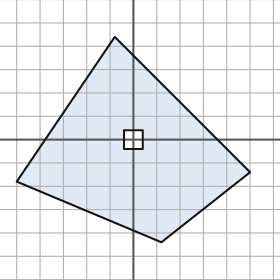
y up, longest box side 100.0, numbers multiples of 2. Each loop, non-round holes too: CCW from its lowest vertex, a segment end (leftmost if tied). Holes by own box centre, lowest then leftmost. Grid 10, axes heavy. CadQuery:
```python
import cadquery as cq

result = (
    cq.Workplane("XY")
    .moveTo(12.0, -44.0)
    .lineTo(50.0, -14.0)
    .lineTo(-8.0, 44.0)
    .lineTo(-50.0, -18.0)
    .close()
    .moveTo(-4.0, -4.0)
    .lineTo(4.0, -4.0)
    .lineTo(4.0, 4.0)
    .lineTo(-4.0, 4.0)
    .close()
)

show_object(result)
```